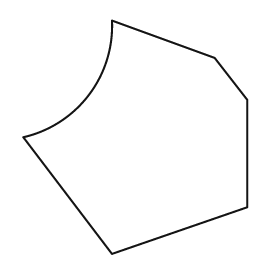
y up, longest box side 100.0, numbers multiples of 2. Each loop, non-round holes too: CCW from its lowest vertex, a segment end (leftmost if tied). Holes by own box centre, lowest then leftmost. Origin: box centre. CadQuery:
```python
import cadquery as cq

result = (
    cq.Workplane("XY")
    .moveTo(-10.0, -50.0)
    .lineTo(48.0, -30.0)
    .lineTo(48.0, 16.0)
    .lineTo(34.0, 34.0)
    .lineTo(-10.0, 50.0)
    .threePointArc((-20.0, 18.0), (-48.0, 0.0))
    .close()
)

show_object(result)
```